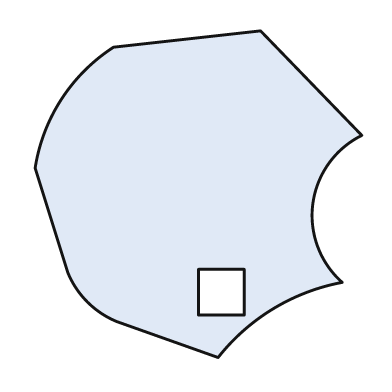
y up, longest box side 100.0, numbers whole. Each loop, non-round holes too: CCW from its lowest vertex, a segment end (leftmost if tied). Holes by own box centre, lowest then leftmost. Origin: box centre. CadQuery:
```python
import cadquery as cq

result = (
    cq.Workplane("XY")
    .moveTo(6.0, -50.0)
    .threePointArc((23.0, -35.0), (44.0, -27.0))
    .threePointArc((35.0, -3.0), (50.0, 18.0))
    .lineTo(19.0, 50.0)
    .lineTo(-26.0, 45.0)
    .threePointArc((-42.0, 29.0), (-50.0, 8.0))
    .lineTo(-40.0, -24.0)
    .threePointArc((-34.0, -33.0), (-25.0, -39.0))
    .close()
    .moveTo(0.0, -37.0)
    .lineTo(14.0, -37.0)
    .lineTo(14.0, -23.0)
    .lineTo(0.0, -23.0)
    .close()
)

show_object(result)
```